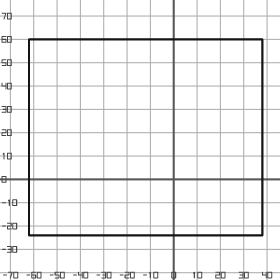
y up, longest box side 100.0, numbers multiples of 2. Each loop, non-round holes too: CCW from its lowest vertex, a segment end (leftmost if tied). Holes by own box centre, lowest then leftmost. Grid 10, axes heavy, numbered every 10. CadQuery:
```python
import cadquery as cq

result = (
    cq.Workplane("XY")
    .moveTo(-62.0, -24.0)
    .lineTo(38.0, -24.0)
    .lineTo(38.0, 60.0)
    .lineTo(-62.0, 60.0)
    .close()
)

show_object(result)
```